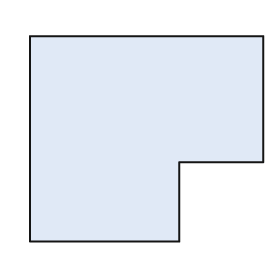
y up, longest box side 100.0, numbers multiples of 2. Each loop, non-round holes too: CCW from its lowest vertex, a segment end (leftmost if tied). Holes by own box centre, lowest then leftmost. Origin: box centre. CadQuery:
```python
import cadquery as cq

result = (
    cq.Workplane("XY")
    .moveTo(-50.0, -44.0)
    .lineTo(14.0, -44.0)
    .lineTo(14.0, -10.0)
    .lineTo(50.0, -10.0)
    .lineTo(50.0, 44.0)
    .lineTo(-50.0, 44.0)
    .close()
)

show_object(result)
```